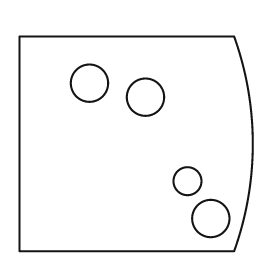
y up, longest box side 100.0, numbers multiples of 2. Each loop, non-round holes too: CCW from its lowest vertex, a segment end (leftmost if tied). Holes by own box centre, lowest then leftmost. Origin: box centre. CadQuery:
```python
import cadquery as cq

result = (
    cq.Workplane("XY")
    .moveTo(-50.0, -46.0)
    .lineTo(42.0, -46.0)
    .threePointArc((50.0, 0.0), (42.0, 46.0))
    .lineTo(-50.0, 46.0)
    .close()
    .moveTo(32.0, -32.0)
    .circle(8.0)
    .moveTo(22.0, -16.0)
    .circle(6.0)
    .moveTo(4.0, 20.0)
    .circle(8.0)
    .moveTo(-20.0, 26.0)
    .circle(8.0)
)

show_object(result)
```